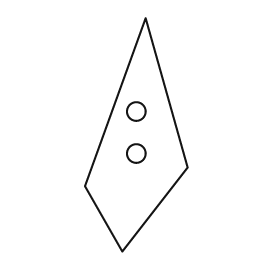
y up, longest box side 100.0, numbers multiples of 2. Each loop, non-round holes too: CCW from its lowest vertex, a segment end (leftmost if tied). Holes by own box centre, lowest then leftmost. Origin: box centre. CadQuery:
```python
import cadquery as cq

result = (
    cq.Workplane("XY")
    .moveTo(-6.0, -50.0)
    .lineTo(22.0, -14.0)
    .lineTo(4.0, 50.0)
    .lineTo(-22.0, -22.0)
    .close()
    .moveTo(0.0, -8.0)
    .circle(4.0)
    .moveTo(0.0, 10.0)
    .circle(4.0)
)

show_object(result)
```